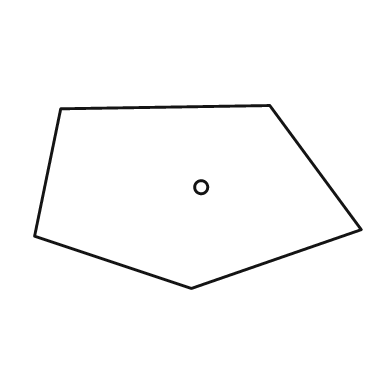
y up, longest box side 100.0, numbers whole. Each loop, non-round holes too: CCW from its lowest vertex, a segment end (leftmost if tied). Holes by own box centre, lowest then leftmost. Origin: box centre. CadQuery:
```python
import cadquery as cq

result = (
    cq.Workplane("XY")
    .moveTo(-2.0, -28.0)
    .lineTo(50.0, -10.0)
    .lineTo(22.0, 28.0)
    .lineTo(-42.0, 27.0)
    .lineTo(-50.0, -12.0)
    .close()
    .moveTo(1.0, 3.0)
    .circle(2.0)
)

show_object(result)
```